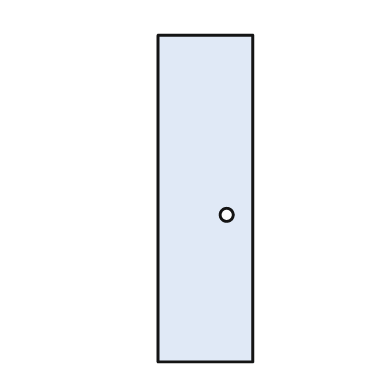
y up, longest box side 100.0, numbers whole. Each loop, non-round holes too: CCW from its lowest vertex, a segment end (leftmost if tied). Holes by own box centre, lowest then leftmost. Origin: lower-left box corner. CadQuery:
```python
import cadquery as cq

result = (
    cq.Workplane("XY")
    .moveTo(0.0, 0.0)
    .lineTo(29.0, 0.0)
    .lineTo(29.0, 100.0)
    .lineTo(0.0, 100.0)
    .close()
    .moveTo(21.0, 45.0)
    .circle(2.0)
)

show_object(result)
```